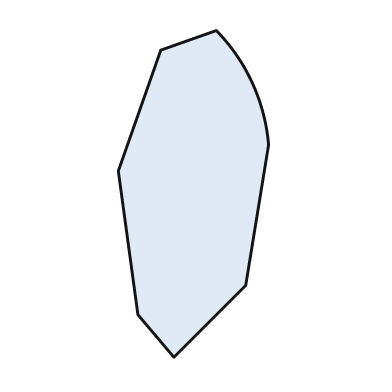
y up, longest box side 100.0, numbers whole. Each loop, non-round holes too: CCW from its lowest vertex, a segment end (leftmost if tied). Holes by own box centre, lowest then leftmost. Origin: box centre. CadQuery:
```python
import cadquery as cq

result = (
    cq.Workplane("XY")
    .moveTo(-6.0, -50.0)
    .lineTo(16.0, -28.0)
    .lineTo(23.0, 15.0)
    .threePointArc((18.0, 34.0), (7.0, 50.0))
    .lineTo(-10.0, 44.0)
    .lineTo(-23.0, 7.0)
    .lineTo(-17.0, -37.0)
    .close()
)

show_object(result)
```